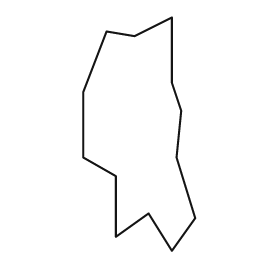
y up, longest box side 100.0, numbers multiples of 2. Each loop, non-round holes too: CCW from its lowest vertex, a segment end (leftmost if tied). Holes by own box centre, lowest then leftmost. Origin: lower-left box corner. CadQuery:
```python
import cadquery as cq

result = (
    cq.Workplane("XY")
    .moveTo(38.0, 0.0)
    .lineTo(48.0, 14.0)
    .lineTo(40.0, 40.0)
    .lineTo(42.0, 60.0)
    .lineTo(38.0, 72.0)
    .lineTo(38.0, 100.0)
    .lineTo(22.0, 92.0)
    .lineTo(10.0, 94.0)
    .lineTo(0.0, 68.0)
    .lineTo(0.0, 40.0)
    .lineTo(14.0, 32.0)
    .lineTo(14.0, 6.0)
    .lineTo(28.0, 16.0)
    .close()
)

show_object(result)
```